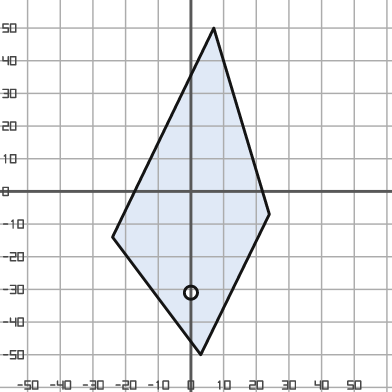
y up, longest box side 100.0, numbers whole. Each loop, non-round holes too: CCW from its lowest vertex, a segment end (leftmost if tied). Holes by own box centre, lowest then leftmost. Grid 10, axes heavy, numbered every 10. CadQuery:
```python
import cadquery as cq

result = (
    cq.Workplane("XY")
    .moveTo(3.0, -50.0)
    .lineTo(24.0, -7.0)
    .lineTo(7.0, 50.0)
    .lineTo(-24.0, -14.0)
    .close()
    .moveTo(0.0, -31.0)
    .circle(2.0)
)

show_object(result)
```